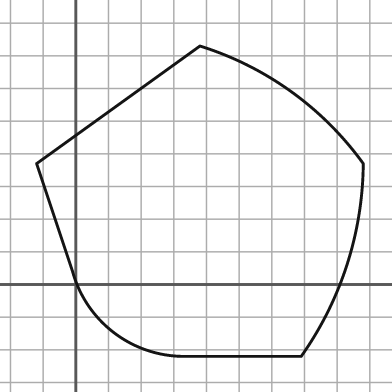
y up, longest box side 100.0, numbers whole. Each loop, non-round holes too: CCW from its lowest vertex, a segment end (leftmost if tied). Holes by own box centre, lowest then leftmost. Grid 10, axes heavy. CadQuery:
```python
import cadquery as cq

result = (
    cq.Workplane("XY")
    .moveTo(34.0, -22.0)
    .lineTo(69.0, -22.0)
    .threePointArc((83.0, 6.0), (88.0, 37.0))
    .threePointArc((66.0, 59.0), (38.0, 73.0))
    .lineTo(-12.0, 37.0)
    .lineTo(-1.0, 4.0)
    .threePointArc((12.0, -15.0), (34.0, -22.0))
    .close()
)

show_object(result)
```